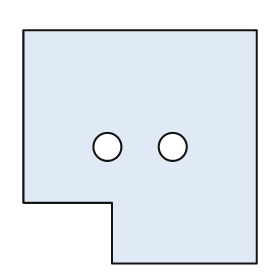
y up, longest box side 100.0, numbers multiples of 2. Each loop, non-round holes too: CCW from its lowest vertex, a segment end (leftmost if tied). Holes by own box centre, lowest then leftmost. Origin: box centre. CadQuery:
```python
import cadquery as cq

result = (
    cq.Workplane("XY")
    .moveTo(-12.0, -50.0)
    .lineTo(50.0, -50.0)
    .lineTo(50.0, 50.0)
    .lineTo(-50.0, 50.0)
    .lineTo(-50.0, -24.0)
    .lineTo(-12.0, -24.0)
    .close()
    .moveTo(-14.0, 0.0)
    .circle(6.0)
    .moveTo(14.0, 0.0)
    .circle(6.0)
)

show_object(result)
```